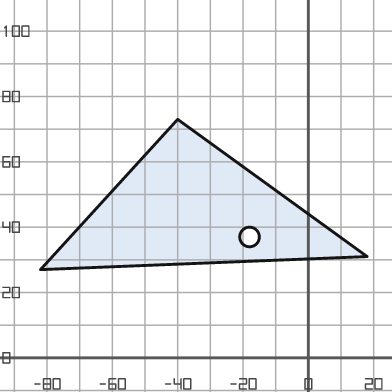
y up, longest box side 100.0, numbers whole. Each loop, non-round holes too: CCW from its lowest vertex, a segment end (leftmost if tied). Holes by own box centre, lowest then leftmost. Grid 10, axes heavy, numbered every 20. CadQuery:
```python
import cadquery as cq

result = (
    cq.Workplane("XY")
    .moveTo(-82.0, 27.0)
    .lineTo(18.0, 31.0)
    .lineTo(-40.0, 73.0)
    .close()
    .moveTo(-18.0, 37.0)
    .circle(3.0)
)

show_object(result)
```